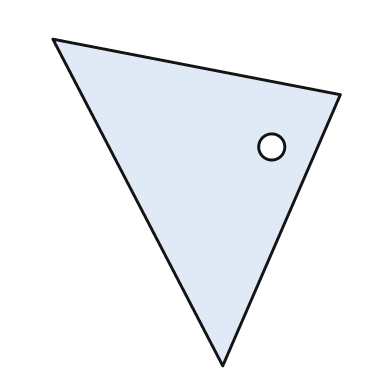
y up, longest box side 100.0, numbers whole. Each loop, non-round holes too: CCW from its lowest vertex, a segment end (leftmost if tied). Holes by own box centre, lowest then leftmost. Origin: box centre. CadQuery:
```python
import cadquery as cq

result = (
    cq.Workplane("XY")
    .moveTo(8.0, -50.0)
    .lineTo(44.0, 33.0)
    .lineTo(-44.0, 50.0)
    .close()
    .moveTo(23.0, 17.0)
    .circle(4.0)
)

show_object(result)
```